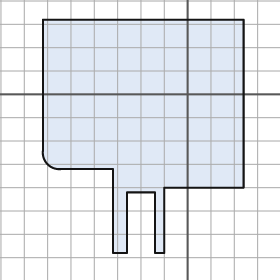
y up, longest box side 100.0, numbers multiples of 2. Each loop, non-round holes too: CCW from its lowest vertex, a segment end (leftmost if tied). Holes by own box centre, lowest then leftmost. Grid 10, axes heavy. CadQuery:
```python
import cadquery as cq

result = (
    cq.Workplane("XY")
    .moveTo(-32.0, -68.0)
    .lineTo(-26.0, -68.0)
    .lineTo(-26.0, -42.0)
    .lineTo(-14.0, -42.0)
    .lineTo(-14.0, -68.0)
    .lineTo(-10.0, -68.0)
    .lineTo(-10.0, -40.0)
    .lineTo(24.0, -40.0)
    .lineTo(24.0, 32.0)
    .lineTo(-62.0, 32.0)
    .lineTo(-62.0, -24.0)
    .threePointArc((-60.0, -30.0), (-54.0, -32.0))
    .lineTo(-32.0, -32.0)
    .close()
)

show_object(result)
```